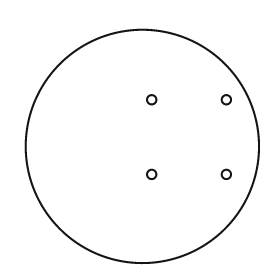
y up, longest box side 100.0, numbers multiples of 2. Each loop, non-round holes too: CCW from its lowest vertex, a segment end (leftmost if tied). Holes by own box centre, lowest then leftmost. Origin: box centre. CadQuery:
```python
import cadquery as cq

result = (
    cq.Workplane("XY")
    .moveTo(0.0, 0.0)
    .circle(50.0)
    .moveTo(4.0, -12.0)
    .circle(2.0)
    .moveTo(36.0, -12.0)
    .circle(2.0)
    .moveTo(4.0, 20.0)
    .circle(2.0)
    .moveTo(36.0, 20.0)
    .circle(2.0)
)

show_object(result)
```